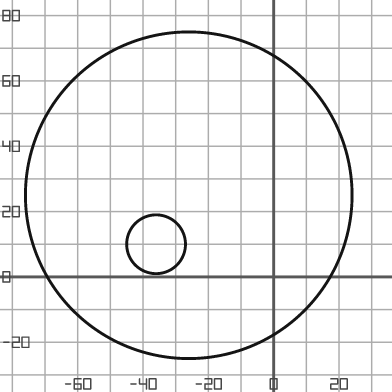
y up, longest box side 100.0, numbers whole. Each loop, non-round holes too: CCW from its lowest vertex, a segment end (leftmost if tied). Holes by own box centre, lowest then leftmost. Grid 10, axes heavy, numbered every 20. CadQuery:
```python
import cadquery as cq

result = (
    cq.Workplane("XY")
    .moveTo(-26.0, 25.0)
    .circle(50.0)
    .moveTo(-36.0, 10.0)
    .circle(9.0)
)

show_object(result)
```